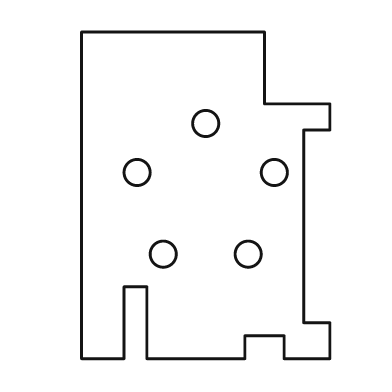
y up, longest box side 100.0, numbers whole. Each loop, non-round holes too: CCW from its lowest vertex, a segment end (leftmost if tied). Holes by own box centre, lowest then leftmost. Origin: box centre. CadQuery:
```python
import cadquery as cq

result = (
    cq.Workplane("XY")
    .moveTo(-38.0, -50.0)
    .lineTo(-25.0, -50.0)
    .lineTo(-25.0, -28.0)
    .lineTo(-18.0, -28.0)
    .lineTo(-18.0, -50.0)
    .lineTo(12.0, -50.0)
    .lineTo(12.0, -43.0)
    .lineTo(24.0, -43.0)
    .lineTo(24.0, -50.0)
    .lineTo(38.0, -50.0)
    .lineTo(38.0, -39.0)
    .lineTo(30.0, -39.0)
    .lineTo(30.0, 20.0)
    .lineTo(38.0, 20.0)
    .lineTo(38.0, 28.0)
    .lineTo(18.0, 28.0)
    .lineTo(18.0, 50.0)
    .lineTo(-38.0, 50.0)
    .close()
    .moveTo(-13.0, -18.0)
    .circle(4.0)
    .moveTo(13.0, -18.0)
    .circle(4.0)
    .moveTo(-21.0, 7.0)
    .circle(4.0)
    .moveTo(21.0, 7.0)
    .circle(4.0)
    .moveTo(0.0, 22.0)
    .circle(4.0)
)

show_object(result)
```